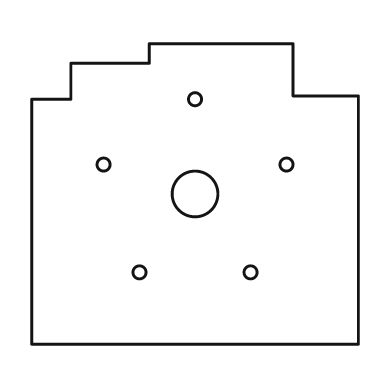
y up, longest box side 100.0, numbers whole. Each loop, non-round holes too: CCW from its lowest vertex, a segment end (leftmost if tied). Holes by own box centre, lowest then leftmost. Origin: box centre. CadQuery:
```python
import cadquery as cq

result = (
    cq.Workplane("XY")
    .moveTo(-50.0, -46.0)
    .lineTo(50.0, -46.0)
    .lineTo(50.0, 30.0)
    .lineTo(30.0, 30.0)
    .lineTo(30.0, 46.0)
    .lineTo(-14.0, 46.0)
    .lineTo(-14.0, 40.0)
    .lineTo(-38.0, 40.0)
    .lineTo(-38.0, 29.0)
    .lineTo(-50.0, 29.0)
    .close()
    .moveTo(-17.0, -24.0)
    .circle(2.0)
    .moveTo(17.0, -24.0)
    .circle(2.0)
    .moveTo(0.0, 0.0)
    .circle(7.0)
    .moveTo(-28.0, 9.0)
    .circle(2.0)
    .moveTo(28.0, 9.0)
    .circle(2.0)
    .moveTo(0.0, 29.0)
    .circle(2.0)
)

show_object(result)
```